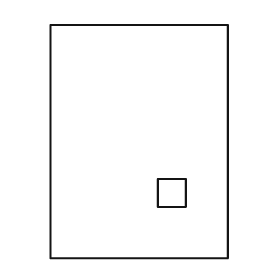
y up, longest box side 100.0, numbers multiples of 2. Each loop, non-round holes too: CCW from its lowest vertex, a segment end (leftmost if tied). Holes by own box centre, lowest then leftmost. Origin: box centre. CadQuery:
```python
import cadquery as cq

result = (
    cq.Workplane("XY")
    .moveTo(-38.0, -50.0)
    .lineTo(38.0, -50.0)
    .lineTo(38.0, 50.0)
    .lineTo(-38.0, 50.0)
    .close()
    .moveTo(8.0, -28.0)
    .lineTo(20.0, -28.0)
    .lineTo(20.0, -16.0)
    .lineTo(8.0, -16.0)
    .close()
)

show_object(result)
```